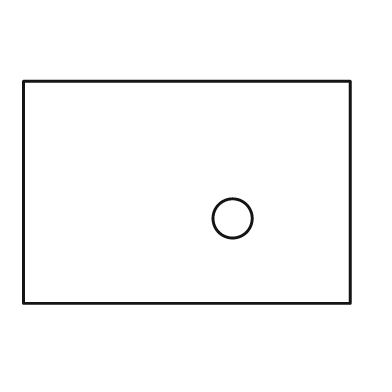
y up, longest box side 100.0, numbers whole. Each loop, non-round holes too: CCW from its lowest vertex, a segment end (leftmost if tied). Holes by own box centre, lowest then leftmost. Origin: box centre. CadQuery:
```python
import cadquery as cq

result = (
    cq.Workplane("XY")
    .moveTo(-50.0, -34.0)
    .lineTo(50.0, -34.0)
    .lineTo(50.0, 34.0)
    .lineTo(-50.0, 34.0)
    .close()
    .moveTo(14.0, -8.0)
    .circle(6.0)
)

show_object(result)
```